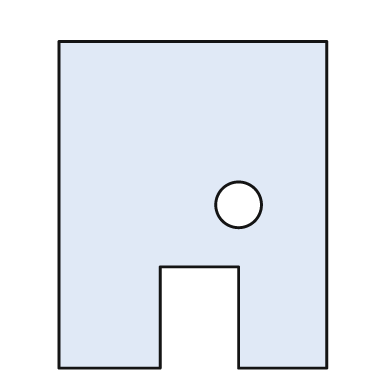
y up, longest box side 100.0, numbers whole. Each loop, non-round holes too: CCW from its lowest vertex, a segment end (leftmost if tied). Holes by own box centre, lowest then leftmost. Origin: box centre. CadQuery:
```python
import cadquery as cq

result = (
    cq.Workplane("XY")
    .moveTo(-41.0, -50.0)
    .lineTo(-10.0, -50.0)
    .lineTo(-10.0, -19.0)
    .lineTo(14.0, -19.0)
    .lineTo(14.0, -50.0)
    .lineTo(41.0, -50.0)
    .lineTo(41.0, 50.0)
    .lineTo(-41.0, 50.0)
    .close()
    .moveTo(14.0, 0.0)
    .circle(7.0)
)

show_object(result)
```